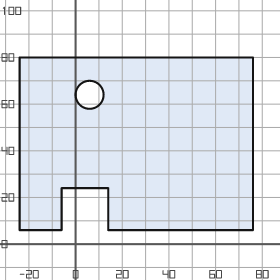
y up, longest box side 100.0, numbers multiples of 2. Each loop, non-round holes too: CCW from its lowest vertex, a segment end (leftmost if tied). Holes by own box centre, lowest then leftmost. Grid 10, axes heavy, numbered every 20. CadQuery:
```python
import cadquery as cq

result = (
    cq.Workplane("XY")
    .moveTo(-24.0, 6.0)
    .lineTo(-6.0, 6.0)
    .lineTo(-6.0, 24.0)
    .lineTo(14.0, 24.0)
    .lineTo(14.0, 6.0)
    .lineTo(76.0, 6.0)
    .lineTo(76.0, 80.0)
    .lineTo(-24.0, 80.0)
    .close()
    .moveTo(6.0, 64.0)
    .circle(6.0)
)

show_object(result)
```